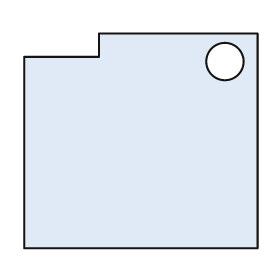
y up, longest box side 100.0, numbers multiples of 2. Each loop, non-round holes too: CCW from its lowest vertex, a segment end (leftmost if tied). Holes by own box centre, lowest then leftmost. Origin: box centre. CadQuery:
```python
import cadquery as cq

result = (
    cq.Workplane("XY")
    .moveTo(-50.0, -46.0)
    .lineTo(50.0, -46.0)
    .lineTo(50.0, 46.0)
    .lineTo(-18.0, 46.0)
    .lineTo(-18.0, 36.0)
    .lineTo(-50.0, 36.0)
    .close()
    .moveTo(36.0, 34.0)
    .circle(8.0)
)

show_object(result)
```